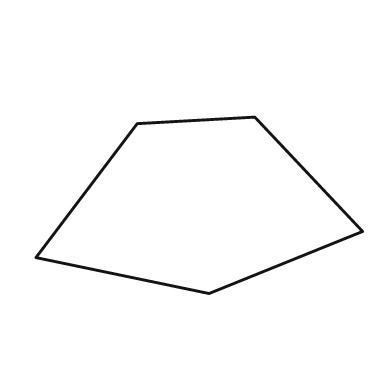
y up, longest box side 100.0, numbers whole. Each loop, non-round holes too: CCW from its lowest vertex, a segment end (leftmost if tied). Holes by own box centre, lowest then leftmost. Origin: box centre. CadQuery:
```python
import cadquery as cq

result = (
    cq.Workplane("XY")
    .moveTo(3.0, -27.0)
    .lineTo(50.0, -8.0)
    .lineTo(17.0, 27.0)
    .lineTo(-19.0, 25.0)
    .lineTo(-50.0, -16.0)
    .close()
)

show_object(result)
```